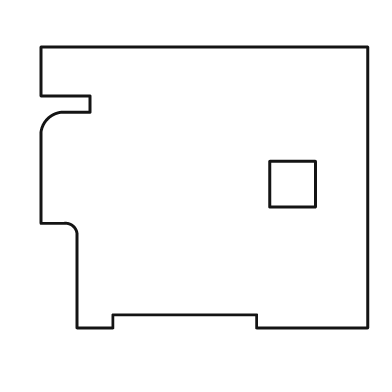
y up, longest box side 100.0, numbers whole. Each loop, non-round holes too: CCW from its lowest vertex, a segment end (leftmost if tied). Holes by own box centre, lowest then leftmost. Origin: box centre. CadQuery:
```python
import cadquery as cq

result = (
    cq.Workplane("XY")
    .moveTo(-39.0, -43.0)
    .lineTo(-28.0, -43.0)
    .lineTo(-28.0, -39.0)
    .lineTo(16.0, -39.0)
    .lineTo(16.0, -43.0)
    .lineTo(50.0, -43.0)
    .lineTo(50.0, 43.0)
    .lineTo(-50.0, 43.0)
    .lineTo(-50.0, 28.0)
    .lineTo(-35.0, 28.0)
    .lineTo(-35.0, 23.0)
    .lineTo(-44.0, 23.0)
    .threePointArc((-48.0, 21.0), (-50.0, 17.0))
    .lineTo(-50.0, -11.0)
    .lineTo(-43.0, -11.0)
    .threePointArc((-40.0, -12.0), (-39.0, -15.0))
    .close()
    .moveTo(20.0, -6.0)
    .lineTo(34.0, -6.0)
    .lineTo(34.0, 8.0)
    .lineTo(20.0, 8.0)
    .close()
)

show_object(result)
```